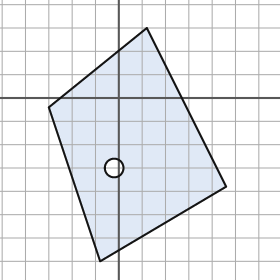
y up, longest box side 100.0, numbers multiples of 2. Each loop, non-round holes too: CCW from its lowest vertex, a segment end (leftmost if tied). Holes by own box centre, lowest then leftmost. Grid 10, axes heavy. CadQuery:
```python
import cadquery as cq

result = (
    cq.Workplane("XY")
    .moveTo(-8.0, -70.0)
    .lineTo(46.0, -38.0)
    .lineTo(12.0, 30.0)
    .lineTo(-30.0, -4.0)
    .close()
    .moveTo(-2.0, -30.0)
    .circle(4.0)
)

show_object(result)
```